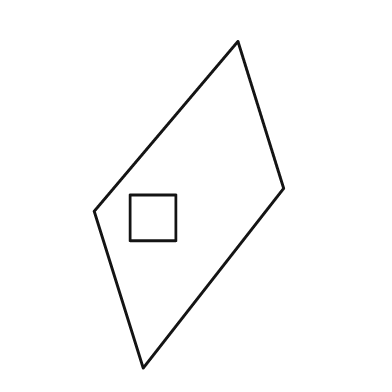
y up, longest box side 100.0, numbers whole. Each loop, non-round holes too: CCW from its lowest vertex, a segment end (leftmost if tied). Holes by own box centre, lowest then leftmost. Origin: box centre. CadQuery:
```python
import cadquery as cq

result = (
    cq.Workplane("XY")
    .moveTo(-14.0, -50.0)
    .lineTo(29.0, 5.0)
    .lineTo(15.0, 50.0)
    .lineTo(-29.0, -2.0)
    .close()
    .moveTo(-18.0, -11.0)
    .lineTo(-4.0, -11.0)
    .lineTo(-4.0, 3.0)
    .lineTo(-18.0, 3.0)
    .close()
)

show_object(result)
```